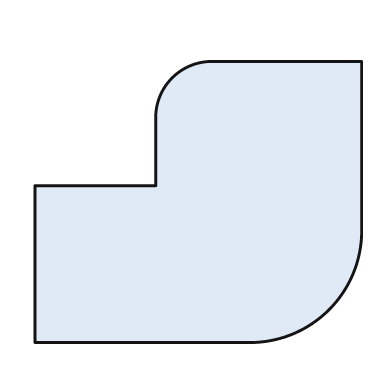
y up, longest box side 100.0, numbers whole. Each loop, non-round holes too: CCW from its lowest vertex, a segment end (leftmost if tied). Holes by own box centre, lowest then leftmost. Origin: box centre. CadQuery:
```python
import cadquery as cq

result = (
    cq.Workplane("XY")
    .moveTo(-50.0, -43.0)
    .lineTo(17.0, -43.0)
    .threePointArc((40.0, -33.0), (50.0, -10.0))
    .lineTo(50.0, 43.0)
    .lineTo(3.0, 43.0)
    .threePointArc((-8.0, 38.0), (-13.0, 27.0))
    .lineTo(-13.0, 5.0)
    .lineTo(-50.0, 5.0)
    .close()
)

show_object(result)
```